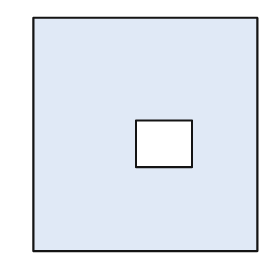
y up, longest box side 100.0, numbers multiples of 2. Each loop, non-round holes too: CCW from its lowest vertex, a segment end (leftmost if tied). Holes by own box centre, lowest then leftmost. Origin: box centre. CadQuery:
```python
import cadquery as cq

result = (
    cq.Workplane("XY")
    .moveTo(-48.0, -50.0)
    .lineTo(48.0, -50.0)
    .lineTo(48.0, 50.0)
    .lineTo(-48.0, 50.0)
    .close()
    .moveTo(-4.0, -14.0)
    .lineTo(20.0, -14.0)
    .lineTo(20.0, 6.0)
    .lineTo(-4.0, 6.0)
    .close()
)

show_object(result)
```